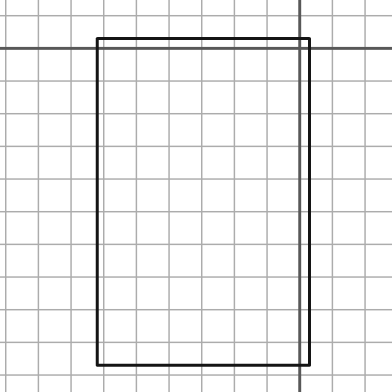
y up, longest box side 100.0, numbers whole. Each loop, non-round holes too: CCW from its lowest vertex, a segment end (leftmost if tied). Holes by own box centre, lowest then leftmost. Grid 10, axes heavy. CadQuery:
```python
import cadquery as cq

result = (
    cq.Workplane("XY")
    .moveTo(-62.0, -97.0)
    .lineTo(3.0, -97.0)
    .lineTo(3.0, 3.0)
    .lineTo(-62.0, 3.0)
    .close()
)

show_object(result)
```